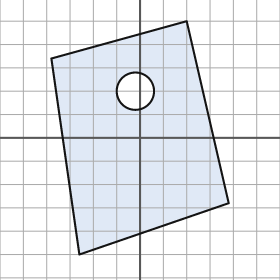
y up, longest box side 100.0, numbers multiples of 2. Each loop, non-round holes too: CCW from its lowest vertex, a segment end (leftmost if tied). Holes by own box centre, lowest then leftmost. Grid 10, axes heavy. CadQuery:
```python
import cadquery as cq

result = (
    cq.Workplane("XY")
    .moveTo(-26.0, -50.0)
    .lineTo(38.0, -28.0)
    .lineTo(20.0, 50.0)
    .lineTo(-38.0, 34.0)
    .close()
    .moveTo(-2.0, 20.0)
    .circle(8.0)
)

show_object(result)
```